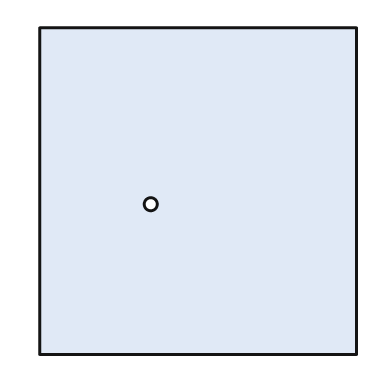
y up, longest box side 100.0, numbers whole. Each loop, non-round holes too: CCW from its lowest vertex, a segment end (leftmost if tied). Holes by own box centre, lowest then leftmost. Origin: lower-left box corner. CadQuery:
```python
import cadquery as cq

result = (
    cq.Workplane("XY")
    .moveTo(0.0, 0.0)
    .lineTo(97.0, 0.0)
    .lineTo(97.0, 100.0)
    .lineTo(0.0, 100.0)
    .close()
    .moveTo(34.0, 46.0)
    .circle(2.0)
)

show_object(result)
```